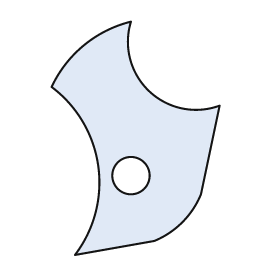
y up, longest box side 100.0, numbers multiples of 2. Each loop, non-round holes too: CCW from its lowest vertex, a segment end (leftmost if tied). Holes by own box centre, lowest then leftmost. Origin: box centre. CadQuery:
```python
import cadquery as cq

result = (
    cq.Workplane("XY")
    .moveTo(-26.0, -50.0)
    .lineTo(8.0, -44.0)
    .threePointArc((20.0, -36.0), (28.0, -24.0))
    .lineTo(36.0, 14.0)
    .threePointArc((6.0, 20.0), (-2.0, 50.0))
    .threePointArc((-22.0, 40.0), (-36.0, 22.0))
    .threePointArc((-16.0, -12.0), (-26.0, -50.0))
    .close()
    .moveTo(-2.0, -16.0)
    .circle(8.0)
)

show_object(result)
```